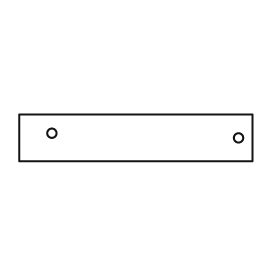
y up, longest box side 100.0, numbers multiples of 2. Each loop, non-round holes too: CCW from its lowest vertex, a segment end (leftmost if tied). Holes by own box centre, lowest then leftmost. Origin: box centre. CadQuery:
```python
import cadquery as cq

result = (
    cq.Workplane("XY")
    .moveTo(-50.0, -10.0)
    .lineTo(50.0, -10.0)
    .lineTo(50.0, 10.0)
    .lineTo(-50.0, 10.0)
    .close()
    .moveTo(44.0, 0.0)
    .circle(2.0)
    .moveTo(-36.0, 2.0)
    .circle(2.0)
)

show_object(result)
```